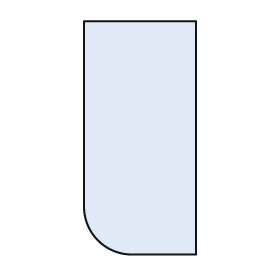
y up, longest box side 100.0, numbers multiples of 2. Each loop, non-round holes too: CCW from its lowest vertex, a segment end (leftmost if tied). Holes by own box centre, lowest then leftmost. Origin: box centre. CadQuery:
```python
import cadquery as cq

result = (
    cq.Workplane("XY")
    .moveTo(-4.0, -50.0)
    .lineTo(24.0, -50.0)
    .lineTo(24.0, 50.0)
    .lineTo(-24.0, 50.0)
    .lineTo(-24.0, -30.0)
    .threePointArc((-18.0, -44.0), (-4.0, -50.0))
    .close()
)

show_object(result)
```